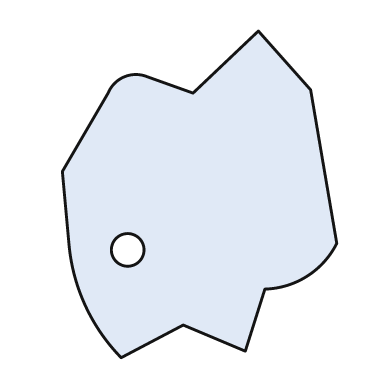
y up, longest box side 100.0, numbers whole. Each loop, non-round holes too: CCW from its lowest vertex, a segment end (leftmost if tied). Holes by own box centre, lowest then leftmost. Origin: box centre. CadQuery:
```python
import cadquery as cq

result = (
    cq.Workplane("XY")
    .moveTo(-24.0, -50.0)
    .lineTo(-5.0, -40.0)
    .lineTo(14.0, -48.0)
    .lineTo(20.0, -29.0)
    .threePointArc((33.0, -25.0), (42.0, -15.0))
    .lineTo(34.0, 32.0)
    .lineTo(18.0, 50.0)
    .lineTo(-2.0, 31.0)
    .lineTo(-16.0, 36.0)
    .threePointArc((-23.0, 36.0), (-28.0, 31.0))
    .lineTo(-42.0, 7.0)
    .lineTo(-40.0, -15.0)
    .threePointArc((-35.0, -34.0), (-24.0, -50.0))
    .close()
    .moveTo(-22.0, -17.0)
    .circle(5.0)
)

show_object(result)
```